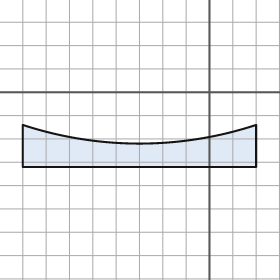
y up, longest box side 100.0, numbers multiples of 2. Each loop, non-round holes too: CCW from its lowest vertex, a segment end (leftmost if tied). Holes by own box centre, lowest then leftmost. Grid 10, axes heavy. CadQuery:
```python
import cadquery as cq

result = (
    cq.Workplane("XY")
    .moveTo(-80.0, -32.0)
    .lineTo(20.0, -32.0)
    .lineTo(20.0, -14.0)
    .threePointArc((-30.0, -22.0), (-80.0, -14.0))
    .close()
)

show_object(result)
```